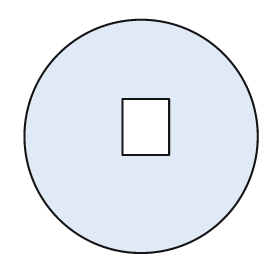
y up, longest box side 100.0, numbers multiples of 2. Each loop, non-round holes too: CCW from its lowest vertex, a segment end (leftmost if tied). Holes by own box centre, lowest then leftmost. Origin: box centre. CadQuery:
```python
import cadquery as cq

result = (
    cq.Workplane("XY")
    .moveTo(0.0, 0.0)
    .circle(50.0)
    .moveTo(-8.0, -8.0)
    .lineTo(12.0, -8.0)
    .lineTo(12.0, 16.0)
    .lineTo(-8.0, 16.0)
    .close()
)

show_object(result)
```